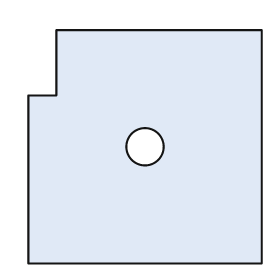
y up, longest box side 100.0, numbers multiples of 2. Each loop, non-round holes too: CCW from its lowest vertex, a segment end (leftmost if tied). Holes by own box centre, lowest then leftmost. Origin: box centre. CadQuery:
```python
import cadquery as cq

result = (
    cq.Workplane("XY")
    .moveTo(-50.0, -50.0)
    .lineTo(50.0, -50.0)
    .lineTo(50.0, 50.0)
    .lineTo(-38.0, 50.0)
    .lineTo(-38.0, 22.0)
    .lineTo(-50.0, 22.0)
    .close()
    .moveTo(0.0, 0.0)
    .circle(8.0)
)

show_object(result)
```